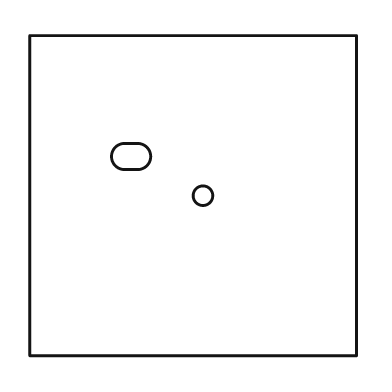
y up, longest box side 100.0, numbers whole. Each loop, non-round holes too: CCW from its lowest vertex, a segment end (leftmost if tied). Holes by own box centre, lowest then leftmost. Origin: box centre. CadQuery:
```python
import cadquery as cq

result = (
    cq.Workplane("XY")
    .moveTo(-50.0, -49.0)
    .lineTo(50.0, -49.0)
    .lineTo(50.0, 49.0)
    .lineTo(-50.0, 49.0)
    .close()
    .moveTo(3.0, 0.0)
    .circle(3.0)
    .moveTo(-21.0, 8.0)
    .lineTo(-17.0, 8.0)
    .threePointArc((-13.0, 12.0), (-17.0, 16.0))
    .lineTo(-21.0, 16.0)
    .threePointArc((-25.0, 12.0), (-21.0, 8.0))
    .close()
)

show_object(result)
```